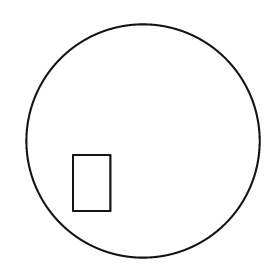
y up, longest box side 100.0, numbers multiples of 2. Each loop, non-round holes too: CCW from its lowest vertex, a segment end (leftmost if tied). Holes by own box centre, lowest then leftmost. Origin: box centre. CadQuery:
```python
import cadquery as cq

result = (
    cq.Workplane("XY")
    .moveTo(0.0, 0.0)
    .circle(50.0)
    .moveTo(-30.0, -30.0)
    .lineTo(-14.0, -30.0)
    .lineTo(-14.0, -6.0)
    .lineTo(-30.0, -6.0)
    .close()
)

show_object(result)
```